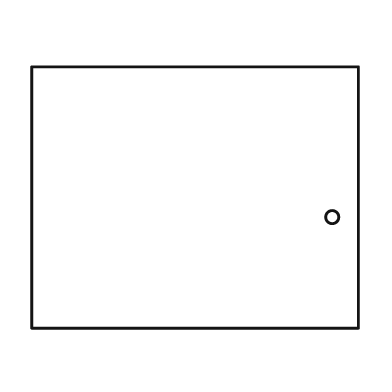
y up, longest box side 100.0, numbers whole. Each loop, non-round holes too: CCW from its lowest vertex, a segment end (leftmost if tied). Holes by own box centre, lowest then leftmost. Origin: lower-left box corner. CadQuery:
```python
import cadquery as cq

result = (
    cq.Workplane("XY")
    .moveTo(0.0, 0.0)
    .lineTo(100.0, 0.0)
    .lineTo(100.0, 80.0)
    .lineTo(0.0, 80.0)
    .close()
    .moveTo(92.0, 34.0)
    .circle(2.0)
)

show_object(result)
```